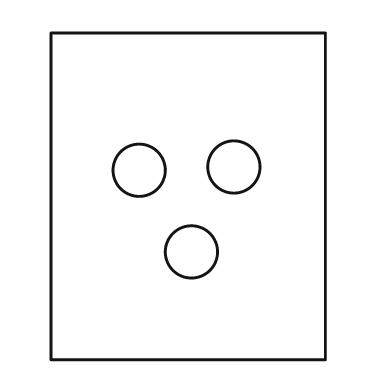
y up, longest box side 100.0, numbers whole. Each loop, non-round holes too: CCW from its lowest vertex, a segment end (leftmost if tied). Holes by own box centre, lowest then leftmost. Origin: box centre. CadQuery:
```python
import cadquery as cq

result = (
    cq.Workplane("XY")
    .moveTo(-42.0, -50.0)
    .lineTo(42.0, -50.0)
    .lineTo(42.0, 50.0)
    .lineTo(-42.0, 50.0)
    .close()
    .moveTo(1.0, -17.0)
    .circle(8.0)
    .moveTo(-15.0, 8.0)
    .circle(8.0)
    .moveTo(14.0, 9.0)
    .circle(8.0)
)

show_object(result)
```